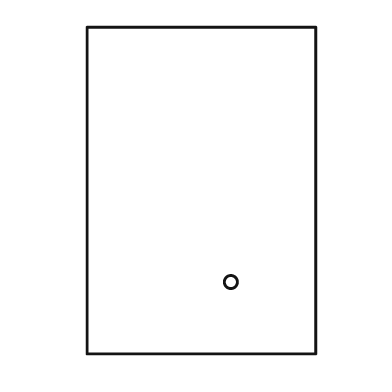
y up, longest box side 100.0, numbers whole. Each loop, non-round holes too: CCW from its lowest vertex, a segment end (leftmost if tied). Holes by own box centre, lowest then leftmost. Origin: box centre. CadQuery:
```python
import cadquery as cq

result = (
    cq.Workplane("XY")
    .moveTo(-35.0, -50.0)
    .lineTo(35.0, -50.0)
    .lineTo(35.0, 50.0)
    .lineTo(-35.0, 50.0)
    .close()
    .moveTo(9.0, -28.0)
    .circle(2.0)
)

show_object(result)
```